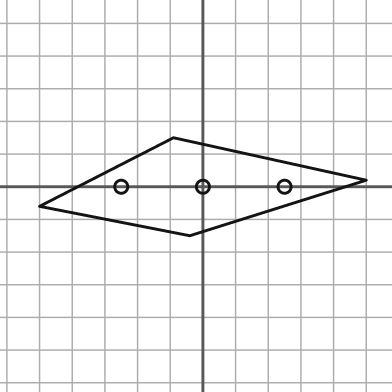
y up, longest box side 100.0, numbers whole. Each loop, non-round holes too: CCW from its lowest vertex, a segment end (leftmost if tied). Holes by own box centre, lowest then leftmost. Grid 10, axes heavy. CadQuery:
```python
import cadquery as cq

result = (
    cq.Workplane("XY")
    .moveTo(-4.0, -15.0)
    .lineTo(50.0, 2.0)
    .lineTo(-9.0, 15.0)
    .lineTo(-50.0, -6.0)
    .close()
    .moveTo(-25.0, 0.0)
    .circle(2.0)
    .moveTo(0.0, 0.0)
    .circle(2.0)
    .moveTo(25.0, 0.0)
    .circle(2.0)
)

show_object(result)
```